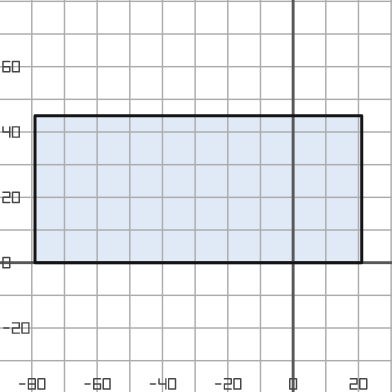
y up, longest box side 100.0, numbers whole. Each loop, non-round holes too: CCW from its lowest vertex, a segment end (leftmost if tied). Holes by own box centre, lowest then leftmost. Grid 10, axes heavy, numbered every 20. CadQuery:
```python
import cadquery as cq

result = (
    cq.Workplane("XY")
    .moveTo(-79.0, 0.0)
    .lineTo(21.0, 0.0)
    .lineTo(21.0, 45.0)
    .lineTo(-79.0, 45.0)
    .close()
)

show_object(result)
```